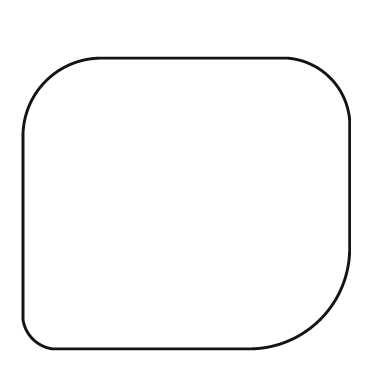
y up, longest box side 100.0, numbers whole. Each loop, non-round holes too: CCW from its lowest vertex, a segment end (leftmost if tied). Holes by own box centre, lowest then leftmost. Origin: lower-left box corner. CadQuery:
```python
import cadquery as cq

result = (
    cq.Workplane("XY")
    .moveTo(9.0, 0.0)
    .lineTo(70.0, 0.0)
    .threePointArc((91.0, 9.0), (100.0, 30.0))
    .lineTo(100.0, 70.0)
    .threePointArc((94.0, 83.0), (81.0, 89.0))
    .lineTo(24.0, 89.0)
    .threePointArc((7.0, 82.0), (0.0, 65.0))
    .lineTo(0.0, 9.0)
    .threePointArc((3.0, 3.0), (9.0, 0.0))
    .close()
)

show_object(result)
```